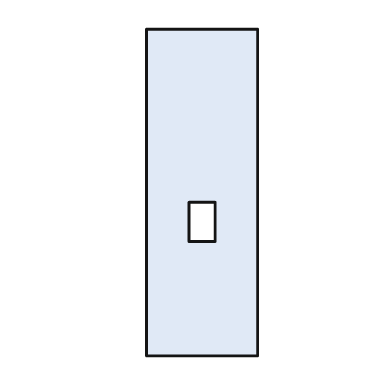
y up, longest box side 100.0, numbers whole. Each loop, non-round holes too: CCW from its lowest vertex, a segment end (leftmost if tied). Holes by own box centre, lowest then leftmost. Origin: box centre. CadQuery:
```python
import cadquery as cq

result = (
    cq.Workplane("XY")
    .moveTo(-17.0, -50.0)
    .lineTo(17.0, -50.0)
    .lineTo(17.0, 50.0)
    .lineTo(-17.0, 50.0)
    .close()
    .moveTo(-4.0, -15.0)
    .lineTo(4.0, -15.0)
    .lineTo(4.0, -3.0)
    .lineTo(-4.0, -3.0)
    .close()
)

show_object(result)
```